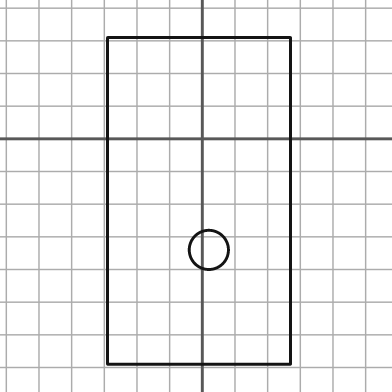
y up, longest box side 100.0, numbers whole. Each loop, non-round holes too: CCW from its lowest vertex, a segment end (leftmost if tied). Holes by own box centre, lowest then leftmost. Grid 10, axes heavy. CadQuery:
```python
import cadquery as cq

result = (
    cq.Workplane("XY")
    .moveTo(-29.0, -69.0)
    .lineTo(27.0, -69.0)
    .lineTo(27.0, 31.0)
    .lineTo(-29.0, 31.0)
    .close()
    .moveTo(2.0, -34.0)
    .circle(6.0)
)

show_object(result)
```